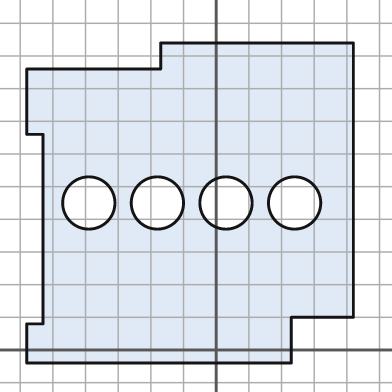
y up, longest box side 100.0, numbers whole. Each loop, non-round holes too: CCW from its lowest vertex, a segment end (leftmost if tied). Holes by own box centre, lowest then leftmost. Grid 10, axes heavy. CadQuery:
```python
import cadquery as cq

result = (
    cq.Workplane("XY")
    .moveTo(-58.0, -4.0)
    .lineTo(23.0, -4.0)
    .lineTo(23.0, 10.0)
    .lineTo(42.0, 10.0)
    .lineTo(42.0, 94.0)
    .lineTo(-17.0, 94.0)
    .lineTo(-17.0, 86.0)
    .lineTo(-58.0, 86.0)
    .lineTo(-58.0, 66.0)
    .lineTo(-53.0, 66.0)
    .lineTo(-53.0, 8.0)
    .lineTo(-58.0, 8.0)
    .close()
    .moveTo(-39.0, 45.0)
    .circle(8.0)
    .moveTo(-18.0, 45.0)
    .circle(8.0)
    .moveTo(3.0, 45.0)
    .circle(8.0)
    .moveTo(24.0, 45.0)
    .circle(8.0)
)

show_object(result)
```